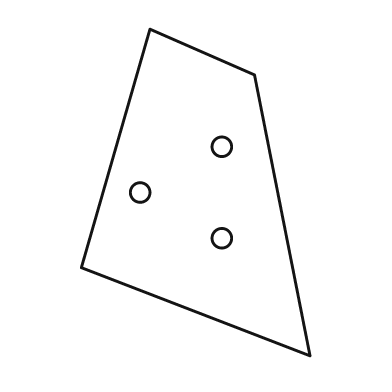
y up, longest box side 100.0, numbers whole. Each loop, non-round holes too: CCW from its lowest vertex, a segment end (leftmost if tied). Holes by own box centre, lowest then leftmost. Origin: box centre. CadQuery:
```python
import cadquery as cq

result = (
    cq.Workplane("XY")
    .moveTo(35.0, -50.0)
    .lineTo(18.0, 36.0)
    .lineTo(-14.0, 50.0)
    .lineTo(-35.0, -23.0)
    .close()
    .moveTo(8.0, -14.0)
    .circle(3.0)
    .moveTo(-17.0, 0.0)
    .circle(3.0)
    .moveTo(8.0, 14.0)
    .circle(3.0)
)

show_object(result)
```